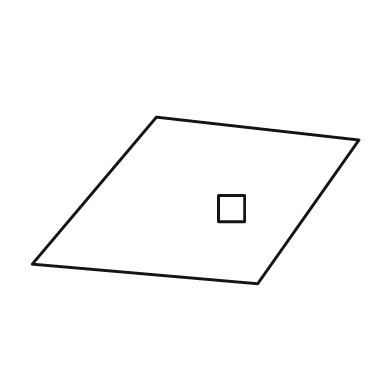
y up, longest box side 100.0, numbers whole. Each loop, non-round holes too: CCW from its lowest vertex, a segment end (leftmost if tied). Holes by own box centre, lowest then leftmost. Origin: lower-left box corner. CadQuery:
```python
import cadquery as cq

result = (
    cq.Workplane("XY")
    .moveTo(69.0, 0.0)
    .lineTo(100.0, 44.0)
    .lineTo(38.0, 51.0)
    .lineTo(0.0, 6.0)
    .close()
    .moveTo(57.0, 19.0)
    .lineTo(65.0, 19.0)
    .lineTo(65.0, 27.0)
    .lineTo(57.0, 27.0)
    .close()
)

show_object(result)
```